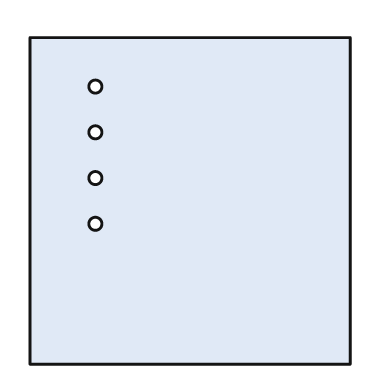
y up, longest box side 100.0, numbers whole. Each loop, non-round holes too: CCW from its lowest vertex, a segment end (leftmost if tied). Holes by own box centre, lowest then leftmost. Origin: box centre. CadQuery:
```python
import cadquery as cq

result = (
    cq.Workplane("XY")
    .moveTo(-49.0, -50.0)
    .lineTo(49.0, -50.0)
    .lineTo(49.0, 50.0)
    .lineTo(-49.0, 50.0)
    .close()
    .moveTo(-29.0, -7.0)
    .circle(2.0)
    .moveTo(-29.0, 7.0)
    .circle(2.0)
    .moveTo(-29.0, 21.0)
    .circle(2.0)
    .moveTo(-29.0, 35.0)
    .circle(2.0)
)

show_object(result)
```